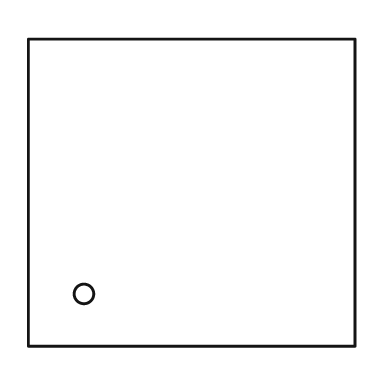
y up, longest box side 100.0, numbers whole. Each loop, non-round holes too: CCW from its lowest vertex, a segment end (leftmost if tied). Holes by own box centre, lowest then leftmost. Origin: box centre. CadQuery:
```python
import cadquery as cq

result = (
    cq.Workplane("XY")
    .moveTo(-50.0, -47.0)
    .lineTo(50.0, -47.0)
    .lineTo(50.0, 47.0)
    .lineTo(-50.0, 47.0)
    .close()
    .moveTo(-33.0, -31.0)
    .circle(3.0)
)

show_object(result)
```